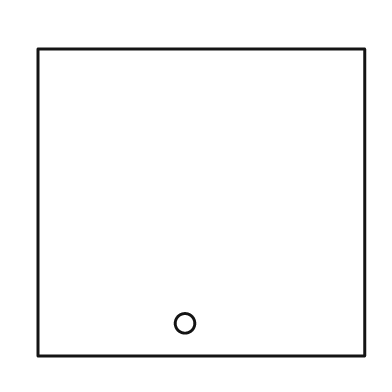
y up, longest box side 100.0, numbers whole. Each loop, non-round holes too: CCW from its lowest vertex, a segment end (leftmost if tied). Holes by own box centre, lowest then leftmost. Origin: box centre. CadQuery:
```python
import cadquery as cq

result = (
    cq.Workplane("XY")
    .moveTo(-50.0, -47.0)
    .lineTo(50.0, -47.0)
    .lineTo(50.0, 47.0)
    .lineTo(-50.0, 47.0)
    .close()
    .moveTo(-5.0, -37.0)
    .circle(3.0)
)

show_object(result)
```